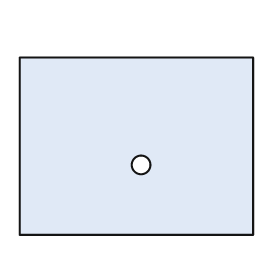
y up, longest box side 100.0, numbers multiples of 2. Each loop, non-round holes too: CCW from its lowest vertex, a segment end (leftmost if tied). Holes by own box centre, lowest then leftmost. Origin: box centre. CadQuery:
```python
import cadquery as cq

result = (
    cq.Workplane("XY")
    .moveTo(-50.0, -38.0)
    .lineTo(50.0, -38.0)
    .lineTo(50.0, 38.0)
    .lineTo(-50.0, 38.0)
    .close()
    .moveTo(2.0, -8.0)
    .circle(4.0)
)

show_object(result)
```